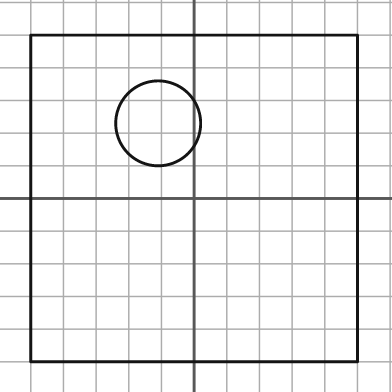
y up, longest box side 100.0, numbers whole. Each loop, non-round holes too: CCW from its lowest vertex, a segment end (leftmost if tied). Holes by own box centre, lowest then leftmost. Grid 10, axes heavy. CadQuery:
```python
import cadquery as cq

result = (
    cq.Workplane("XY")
    .moveTo(-50.0, -50.0)
    .lineTo(50.0, -50.0)
    .lineTo(50.0, 50.0)
    .lineTo(-50.0, 50.0)
    .close()
    .moveTo(-11.0, 23.0)
    .circle(13.0)
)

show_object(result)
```